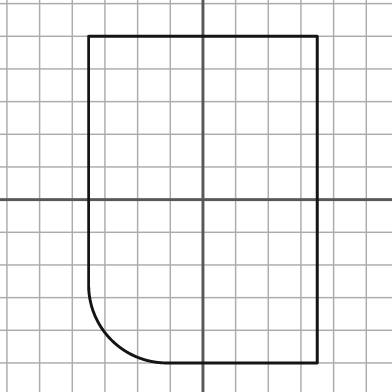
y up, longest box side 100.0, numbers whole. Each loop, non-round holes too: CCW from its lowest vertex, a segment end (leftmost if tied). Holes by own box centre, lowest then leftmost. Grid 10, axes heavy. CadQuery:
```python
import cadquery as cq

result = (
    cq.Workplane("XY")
    .moveTo(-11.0, -50.0)
    .lineTo(35.0, -50.0)
    .lineTo(35.0, 50.0)
    .lineTo(-35.0, 50.0)
    .lineTo(-35.0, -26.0)
    .threePointArc((-28.0, -43.0), (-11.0, -50.0))
    .close()
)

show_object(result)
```